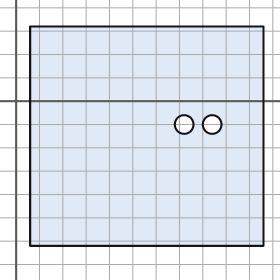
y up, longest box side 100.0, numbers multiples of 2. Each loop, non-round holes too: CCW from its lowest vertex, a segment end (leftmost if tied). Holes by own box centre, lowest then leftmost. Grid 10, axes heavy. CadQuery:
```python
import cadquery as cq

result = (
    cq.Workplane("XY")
    .moveTo(6.0, -62.0)
    .lineTo(106.0, -62.0)
    .lineTo(106.0, 32.0)
    .lineTo(6.0, 32.0)
    .close()
    .moveTo(72.0, -10.0)
    .circle(4.0)
    .moveTo(84.0, -10.0)
    .circle(4.0)
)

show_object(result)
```